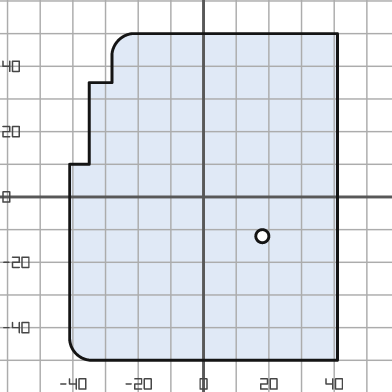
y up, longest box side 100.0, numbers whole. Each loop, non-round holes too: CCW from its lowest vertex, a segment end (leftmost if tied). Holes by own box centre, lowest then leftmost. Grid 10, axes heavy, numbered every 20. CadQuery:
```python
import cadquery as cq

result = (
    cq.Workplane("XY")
    .moveTo(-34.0, -50.0)
    .lineTo(41.0, -50.0)
    .lineTo(41.0, 50.0)
    .lineTo(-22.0, 50.0)
    .threePointArc((-26.0, 48.0), (-28.0, 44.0))
    .lineTo(-28.0, 35.0)
    .lineTo(-35.0, 35.0)
    .lineTo(-35.0, 10.0)
    .lineTo(-41.0, 10.0)
    .lineTo(-41.0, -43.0)
    .threePointArc((-39.0, -48.0), (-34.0, -50.0))
    .close()
    .moveTo(18.0, -12.0)
    .circle(2.0)
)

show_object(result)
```